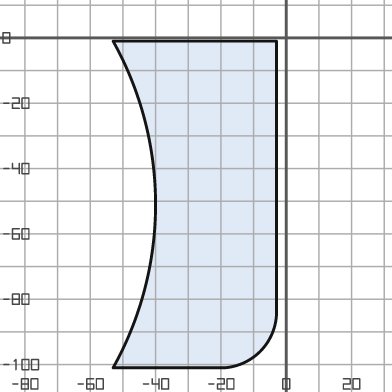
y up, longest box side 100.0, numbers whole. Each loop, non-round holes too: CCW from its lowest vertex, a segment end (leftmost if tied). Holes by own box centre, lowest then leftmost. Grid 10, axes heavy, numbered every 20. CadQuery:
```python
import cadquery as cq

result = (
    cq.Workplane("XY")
    .moveTo(-53.0, -101.0)
    .lineTo(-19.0, -101.0)
    .threePointArc((-8.0, -96.0), (-3.0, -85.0))
    .lineTo(-3.0, -1.0)
    .lineTo(-53.0, -1.0)
    .threePointArc((-40.0, -51.0), (-53.0, -101.0))
    .close()
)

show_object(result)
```